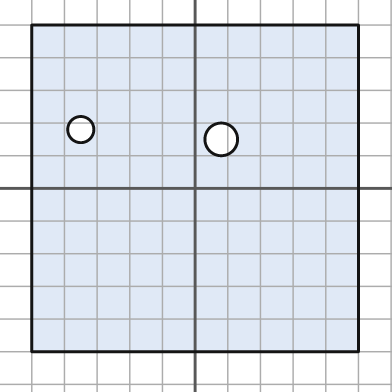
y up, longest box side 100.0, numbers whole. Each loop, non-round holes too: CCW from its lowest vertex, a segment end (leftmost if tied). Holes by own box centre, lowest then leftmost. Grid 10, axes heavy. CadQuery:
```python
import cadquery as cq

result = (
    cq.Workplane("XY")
    .moveTo(-50.0, -50.0)
    .lineTo(50.0, -50.0)
    .lineTo(50.0, 50.0)
    .lineTo(-50.0, 50.0)
    .close()
    .moveTo(8.0, 15.0)
    .circle(5.0)
    .moveTo(-35.0, 18.0)
    .circle(4.0)
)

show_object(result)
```